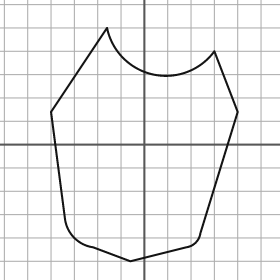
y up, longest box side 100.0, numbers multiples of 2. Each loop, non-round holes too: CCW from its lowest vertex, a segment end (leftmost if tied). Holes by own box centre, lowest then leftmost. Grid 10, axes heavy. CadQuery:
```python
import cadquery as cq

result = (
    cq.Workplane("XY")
    .moveTo(-6.0, -50.0)
    .lineTo(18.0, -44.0)
    .threePointArc((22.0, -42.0), (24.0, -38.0))
    .lineTo(40.0, 14.0)
    .lineTo(30.0, 40.0)
    .threePointArc((4.0, 30.0), (-16.0, 50.0))
    .lineTo(-40.0, 14.0)
    .lineTo(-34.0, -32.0)
    .threePointArc((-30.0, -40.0), (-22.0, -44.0))
    .close()
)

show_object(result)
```